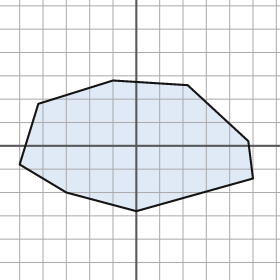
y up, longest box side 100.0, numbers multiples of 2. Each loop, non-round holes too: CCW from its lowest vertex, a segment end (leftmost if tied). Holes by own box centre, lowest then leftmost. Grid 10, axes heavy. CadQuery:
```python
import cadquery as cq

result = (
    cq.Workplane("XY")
    .moveTo(0.0, -28.0)
    .lineTo(50.0, -14.0)
    .lineTo(48.0, 2.0)
    .lineTo(22.0, 26.0)
    .lineTo(-10.0, 28.0)
    .lineTo(-42.0, 18.0)
    .lineTo(-50.0, -8.0)
    .lineTo(-30.0, -20.0)
    .close()
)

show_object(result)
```